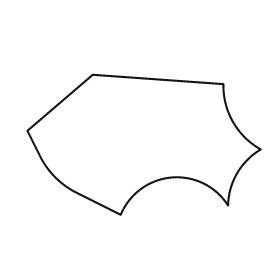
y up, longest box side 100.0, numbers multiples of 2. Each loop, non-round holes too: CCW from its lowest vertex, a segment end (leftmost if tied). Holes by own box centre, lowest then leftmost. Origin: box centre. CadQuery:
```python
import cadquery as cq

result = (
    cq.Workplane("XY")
    .moveTo(-10.0, -30.0)
    .threePointArc((12.0, -14.0), (36.0, -26.0))
    .threePointArc((40.0, -12.0), (50.0, -2.0))
    .threePointArc((38.0, 10.0), (34.0, 26.0))
    .lineTo(-22.0, 30.0)
    .lineTo(-50.0, 6.0)
    .lineTo(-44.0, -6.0)
    .threePointArc((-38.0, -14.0), (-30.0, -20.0))
    .close()
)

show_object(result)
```